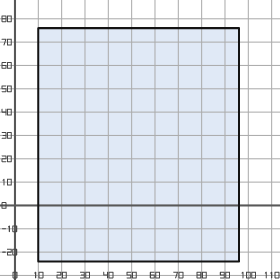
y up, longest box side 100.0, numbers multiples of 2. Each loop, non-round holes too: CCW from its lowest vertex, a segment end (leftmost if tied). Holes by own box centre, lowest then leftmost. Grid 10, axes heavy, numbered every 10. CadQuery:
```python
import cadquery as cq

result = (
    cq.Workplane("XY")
    .moveTo(10.0, -24.0)
    .lineTo(96.0, -24.0)
    .lineTo(96.0, 76.0)
    .lineTo(10.0, 76.0)
    .close()
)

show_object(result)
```